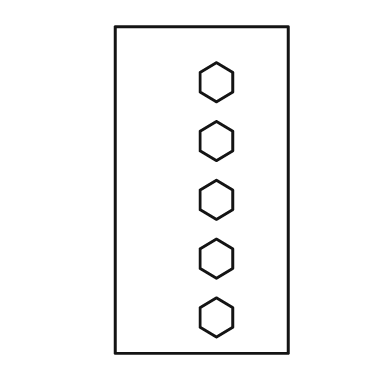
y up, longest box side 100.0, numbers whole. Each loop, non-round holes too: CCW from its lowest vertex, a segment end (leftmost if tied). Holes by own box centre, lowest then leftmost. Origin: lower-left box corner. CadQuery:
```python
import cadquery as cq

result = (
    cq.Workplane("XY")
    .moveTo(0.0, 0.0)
    .lineTo(53.0, 0.0)
    .lineTo(53.0, 100.0)
    .lineTo(0.0, 100.0)
    .close()
    .moveTo(31.0, 5.0)
    .lineTo(36.0, 8.0)
    .lineTo(36.0, 14.0)
    .lineTo(31.0, 17.0)
    .lineTo(26.0, 14.0)
    .lineTo(26.0, 8.0)
    .close()
    .moveTo(31.0, 23.0)
    .lineTo(36.0, 26.0)
    .lineTo(36.0, 32.0)
    .lineTo(31.0, 35.0)
    .lineTo(26.0, 32.0)
    .lineTo(26.0, 26.0)
    .close()
    .moveTo(31.0, 41.0)
    .lineTo(36.0, 44.0)
    .lineTo(36.0, 50.0)
    .lineTo(31.0, 53.0)
    .lineTo(26.0, 50.0)
    .lineTo(26.0, 44.0)
    .close()
    .moveTo(31.0, 59.0)
    .lineTo(36.0, 62.0)
    .lineTo(36.0, 68.0)
    .lineTo(31.0, 71.0)
    .lineTo(26.0, 68.0)
    .lineTo(26.0, 62.0)
    .close()
    .moveTo(31.0, 77.0)
    .lineTo(36.0, 80.0)
    .lineTo(36.0, 86.0)
    .lineTo(31.0, 89.0)
    .lineTo(26.0, 86.0)
    .lineTo(26.0, 80.0)
    .close()
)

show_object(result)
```